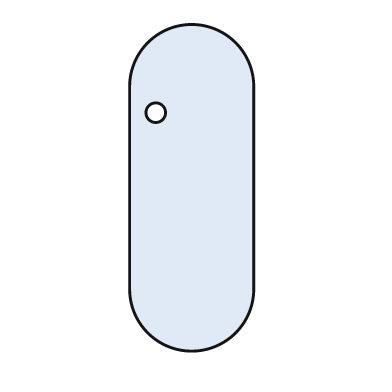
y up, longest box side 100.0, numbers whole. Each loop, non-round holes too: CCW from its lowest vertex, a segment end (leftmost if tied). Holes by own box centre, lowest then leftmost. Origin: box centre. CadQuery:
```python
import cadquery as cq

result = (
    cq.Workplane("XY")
    .moveTo(-19.0, -31.0)
    .threePointArc((0.0, -50.0), (19.0, -31.0))
    .lineTo(19.0, 31.0)
    .threePointArc((0.0, 50.0), (-19.0, 31.0))
    .close()
    .moveTo(-11.0, 23.0)
    .circle(3.0)
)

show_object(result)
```